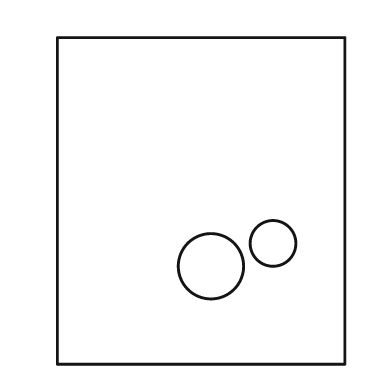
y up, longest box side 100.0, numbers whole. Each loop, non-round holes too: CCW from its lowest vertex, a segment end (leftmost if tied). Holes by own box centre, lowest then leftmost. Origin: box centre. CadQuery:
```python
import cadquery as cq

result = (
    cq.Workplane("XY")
    .moveTo(-44.0, -50.0)
    .lineTo(44.0, -50.0)
    .lineTo(44.0, 50.0)
    .lineTo(-44.0, 50.0)
    .close()
    .moveTo(3.0, -20.0)
    .circle(10.0)
    .moveTo(22.0, -13.0)
    .circle(7.0)
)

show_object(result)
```